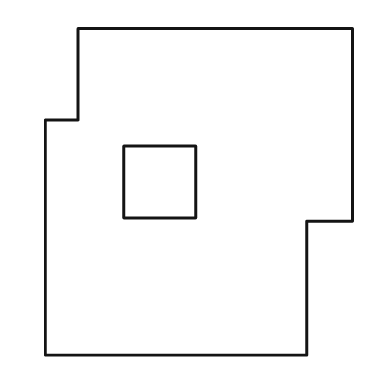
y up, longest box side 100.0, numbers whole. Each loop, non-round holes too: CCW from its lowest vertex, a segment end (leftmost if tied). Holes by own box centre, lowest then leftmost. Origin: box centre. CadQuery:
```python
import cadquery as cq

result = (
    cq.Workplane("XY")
    .moveTo(-47.0, -50.0)
    .lineTo(33.0, -50.0)
    .lineTo(33.0, -9.0)
    .lineTo(47.0, -9.0)
    .lineTo(47.0, 50.0)
    .lineTo(-37.0, 50.0)
    .lineTo(-37.0, 22.0)
    .lineTo(-47.0, 22.0)
    .close()
    .moveTo(-23.0, -8.0)
    .lineTo(-1.0, -8.0)
    .lineTo(-1.0, 14.0)
    .lineTo(-23.0, 14.0)
    .close()
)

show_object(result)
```